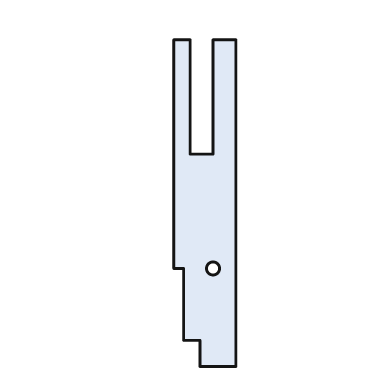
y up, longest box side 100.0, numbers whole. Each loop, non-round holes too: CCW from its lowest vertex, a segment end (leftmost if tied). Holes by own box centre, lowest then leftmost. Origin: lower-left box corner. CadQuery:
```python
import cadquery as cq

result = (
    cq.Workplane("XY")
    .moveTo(8.0, 0.0)
    .lineTo(19.0, 0.0)
    .lineTo(19.0, 100.0)
    .lineTo(12.0, 100.0)
    .lineTo(12.0, 65.0)
    .lineTo(5.0, 65.0)
    .lineTo(5.0, 100.0)
    .lineTo(0.0, 100.0)
    .lineTo(0.0, 30.0)
    .lineTo(3.0, 30.0)
    .lineTo(3.0, 8.0)
    .lineTo(8.0, 8.0)
    .close()
    .moveTo(12.0, 30.0)
    .circle(2.0)
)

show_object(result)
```